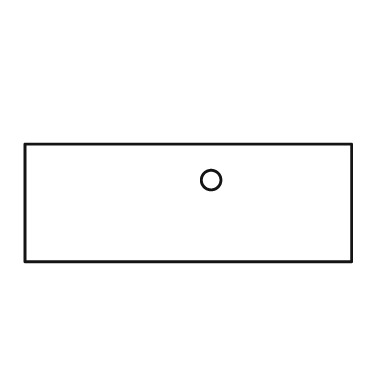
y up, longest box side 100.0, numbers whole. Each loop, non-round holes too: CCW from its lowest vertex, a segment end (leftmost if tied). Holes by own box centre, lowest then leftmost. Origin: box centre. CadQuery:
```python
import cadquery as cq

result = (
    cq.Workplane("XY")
    .moveTo(-50.0, -18.0)
    .lineTo(50.0, -18.0)
    .lineTo(50.0, 18.0)
    .lineTo(-50.0, 18.0)
    .close()
    .moveTo(7.0, 7.0)
    .circle(3.0)
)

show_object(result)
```